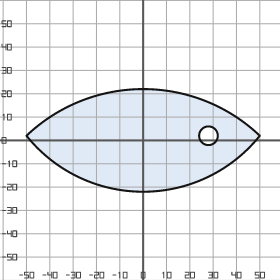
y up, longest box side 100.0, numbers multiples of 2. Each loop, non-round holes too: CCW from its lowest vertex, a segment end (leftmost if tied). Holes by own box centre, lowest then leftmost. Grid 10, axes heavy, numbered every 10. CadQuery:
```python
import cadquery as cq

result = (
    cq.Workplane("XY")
    .moveTo(-50.0, 2.0)
    .threePointArc((0.0, -22.0), (50.0, 2.0))
    .threePointArc((0.0, 22.0), (-50.0, 2.0))
    .close()
    .moveTo(28.0, 2.0)
    .circle(4.0)
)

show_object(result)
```